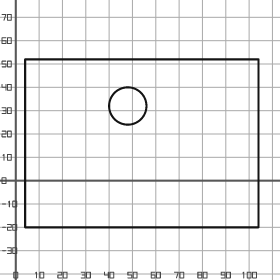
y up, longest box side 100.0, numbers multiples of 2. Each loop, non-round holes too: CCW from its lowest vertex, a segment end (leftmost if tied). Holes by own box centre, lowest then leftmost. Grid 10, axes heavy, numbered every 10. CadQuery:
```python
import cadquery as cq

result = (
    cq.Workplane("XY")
    .moveTo(4.0, -20.0)
    .lineTo(104.0, -20.0)
    .lineTo(104.0, 52.0)
    .lineTo(4.0, 52.0)
    .close()
    .moveTo(48.0, 32.0)
    .circle(8.0)
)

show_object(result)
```